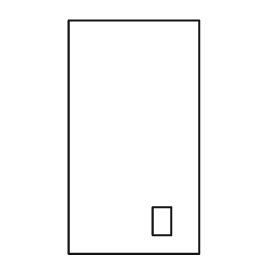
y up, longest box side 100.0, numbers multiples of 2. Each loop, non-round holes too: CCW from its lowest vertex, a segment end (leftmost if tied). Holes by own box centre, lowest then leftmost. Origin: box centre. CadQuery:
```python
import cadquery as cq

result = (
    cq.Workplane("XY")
    .moveTo(-28.0, -50.0)
    .lineTo(28.0, -50.0)
    .lineTo(28.0, 50.0)
    .lineTo(-28.0, 50.0)
    .close()
    .moveTo(8.0, -42.0)
    .lineTo(16.0, -42.0)
    .lineTo(16.0, -30.0)
    .lineTo(8.0, -30.0)
    .close()
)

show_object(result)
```